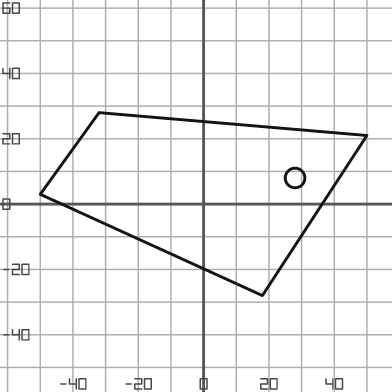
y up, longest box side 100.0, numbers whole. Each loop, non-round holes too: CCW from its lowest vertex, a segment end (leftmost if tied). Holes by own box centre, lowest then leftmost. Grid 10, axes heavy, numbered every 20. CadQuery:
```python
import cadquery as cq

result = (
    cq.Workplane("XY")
    .moveTo(18.0, -28.0)
    .lineTo(50.0, 21.0)
    .lineTo(-32.0, 28.0)
    .lineTo(-50.0, 3.0)
    .close()
    .moveTo(28.0, 8.0)
    .circle(3.0)
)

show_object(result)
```